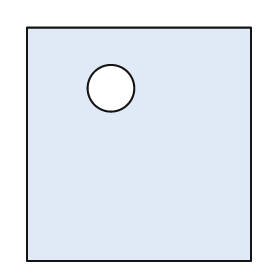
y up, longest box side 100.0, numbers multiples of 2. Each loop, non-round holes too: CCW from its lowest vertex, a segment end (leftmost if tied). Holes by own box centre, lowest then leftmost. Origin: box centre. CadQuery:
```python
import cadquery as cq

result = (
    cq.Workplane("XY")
    .moveTo(-48.0, -50.0)
    .lineTo(48.0, -50.0)
    .lineTo(48.0, 50.0)
    .lineTo(-48.0, 50.0)
    .close()
    .moveTo(-12.0, 24.0)
    .circle(10.0)
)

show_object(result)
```